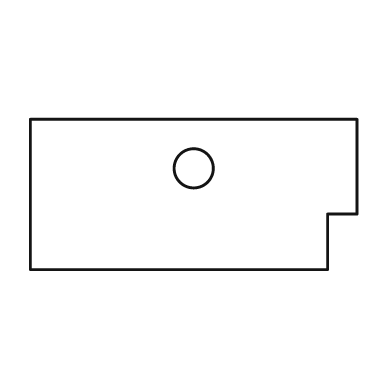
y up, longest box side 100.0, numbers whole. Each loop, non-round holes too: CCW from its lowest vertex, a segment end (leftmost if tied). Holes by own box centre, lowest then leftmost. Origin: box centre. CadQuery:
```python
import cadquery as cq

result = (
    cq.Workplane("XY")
    .moveTo(-50.0, -23.0)
    .lineTo(41.0, -23.0)
    .lineTo(41.0, -6.0)
    .lineTo(50.0, -6.0)
    .lineTo(50.0, 23.0)
    .lineTo(-50.0, 23.0)
    .close()
    .moveTo(0.0, 8.0)
    .circle(6.0)
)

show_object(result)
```